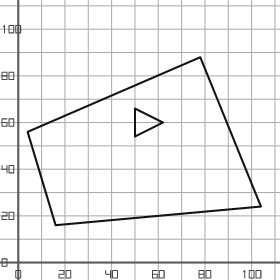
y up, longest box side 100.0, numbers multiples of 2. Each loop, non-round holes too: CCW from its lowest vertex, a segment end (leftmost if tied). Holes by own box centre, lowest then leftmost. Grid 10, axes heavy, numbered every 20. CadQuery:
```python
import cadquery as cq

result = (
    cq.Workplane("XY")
    .moveTo(16.0, 16.0)
    .lineTo(104.0, 24.0)
    .lineTo(78.0, 88.0)
    .lineTo(4.0, 56.0)
    .close()
    .moveTo(50.0, 54.0)
    .lineTo(62.0, 60.0)
    .lineTo(50.0, 66.0)
    .close()
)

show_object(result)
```